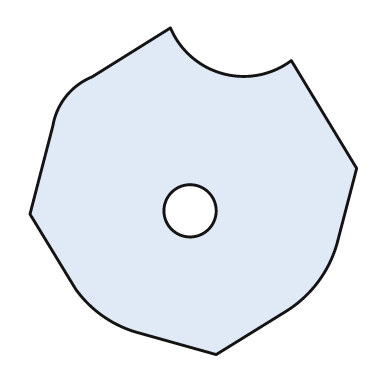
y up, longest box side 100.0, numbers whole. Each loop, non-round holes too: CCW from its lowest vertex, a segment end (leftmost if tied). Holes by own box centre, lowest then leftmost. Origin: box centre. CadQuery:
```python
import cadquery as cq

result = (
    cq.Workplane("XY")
    .moveTo(7.0, -50.0)
    .lineTo(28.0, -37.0)
    .threePointArc((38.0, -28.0), (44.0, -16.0))
    .lineTo(50.0, 7.0)
    .lineTo(30.0, 40.0)
    .threePointArc((9.0, 36.0), (-7.0, 50.0))
    .lineTo(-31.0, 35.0)
    .threePointArc((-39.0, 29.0), (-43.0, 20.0))
    .lineTo(-50.0, -7.0)
    .lineTo(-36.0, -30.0)
    .threePointArc((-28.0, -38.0), (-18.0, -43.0))
    .close()
    .moveTo(-1.0, -6.0)
    .circle(8.0)
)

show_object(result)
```